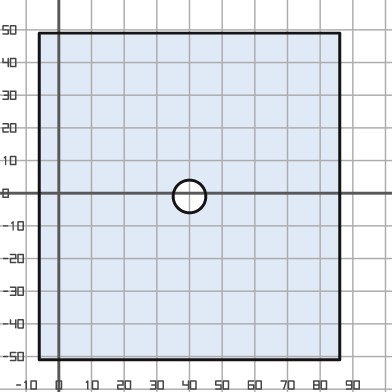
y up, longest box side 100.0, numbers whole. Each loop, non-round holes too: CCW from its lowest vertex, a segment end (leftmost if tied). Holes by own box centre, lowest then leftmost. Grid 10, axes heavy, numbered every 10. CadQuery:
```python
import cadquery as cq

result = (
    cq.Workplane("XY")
    .moveTo(-6.0, -51.0)
    .lineTo(86.0, -51.0)
    .lineTo(86.0, 49.0)
    .lineTo(-6.0, 49.0)
    .close()
    .moveTo(40.0, -1.0)
    .circle(5.0)
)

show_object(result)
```